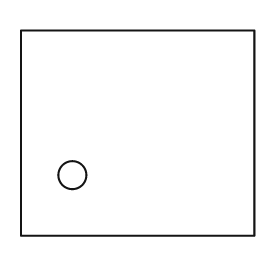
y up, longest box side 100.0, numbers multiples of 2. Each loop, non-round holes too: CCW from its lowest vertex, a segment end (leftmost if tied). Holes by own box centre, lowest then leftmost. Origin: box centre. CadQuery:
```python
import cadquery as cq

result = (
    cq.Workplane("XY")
    .moveTo(-50.0, -44.0)
    .lineTo(50.0, -44.0)
    .lineTo(50.0, 44.0)
    .lineTo(-50.0, 44.0)
    .close()
    .moveTo(-28.0, -18.0)
    .circle(6.0)
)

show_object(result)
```